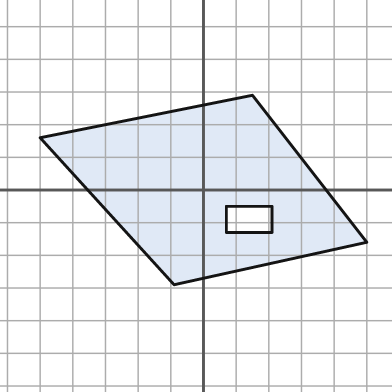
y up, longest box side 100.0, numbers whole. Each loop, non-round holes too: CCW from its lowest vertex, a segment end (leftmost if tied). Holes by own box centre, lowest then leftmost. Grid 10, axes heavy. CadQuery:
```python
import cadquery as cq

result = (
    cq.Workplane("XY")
    .moveTo(-9.0, -29.0)
    .lineTo(50.0, -16.0)
    .lineTo(15.0, 29.0)
    .lineTo(-50.0, 16.0)
    .close()
    .moveTo(7.0, -13.0)
    .lineTo(21.0, -13.0)
    .lineTo(21.0, -5.0)
    .lineTo(7.0, -5.0)
    .close()
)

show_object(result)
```